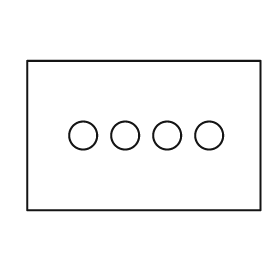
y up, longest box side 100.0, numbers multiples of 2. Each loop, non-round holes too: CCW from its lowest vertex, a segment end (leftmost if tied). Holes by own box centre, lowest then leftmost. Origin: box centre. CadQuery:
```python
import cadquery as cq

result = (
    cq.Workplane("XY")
    .moveTo(-50.0, -32.0)
    .lineTo(50.0, -32.0)
    .lineTo(50.0, 32.0)
    .lineTo(-50.0, 32.0)
    .close()
    .moveTo(-26.0, 0.0)
    .circle(6.0)
    .moveTo(-8.0, 0.0)
    .circle(6.0)
    .moveTo(10.0, 0.0)
    .circle(6.0)
    .moveTo(28.0, 0.0)
    .circle(6.0)
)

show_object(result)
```